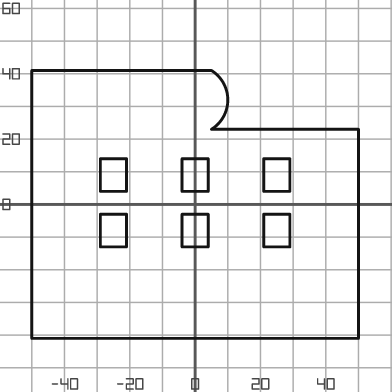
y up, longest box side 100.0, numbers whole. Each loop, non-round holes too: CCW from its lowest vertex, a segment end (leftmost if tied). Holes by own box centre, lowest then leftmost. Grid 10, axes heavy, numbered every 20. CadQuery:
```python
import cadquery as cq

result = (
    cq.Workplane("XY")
    .moveTo(-50.0, -41.0)
    .lineTo(50.0, -41.0)
    .lineTo(50.0, 23.0)
    .lineTo(5.0, 23.0)
    .threePointArc((10.0, 32.0), (5.0, 41.0))
    .lineTo(-50.0, 41.0)
    .close()
    .moveTo(-29.0, -13.0)
    .lineTo(-21.0, -13.0)
    .lineTo(-21.0, -3.0)
    .lineTo(-29.0, -3.0)
    .close()
    .moveTo(-4.0, -13.0)
    .lineTo(4.0, -13.0)
    .lineTo(4.0, -3.0)
    .lineTo(-4.0, -3.0)
    .close()
    .moveTo(21.0, -13.0)
    .lineTo(29.0, -13.0)
    .lineTo(29.0, -3.0)
    .lineTo(21.0, -3.0)
    .close()
    .moveTo(-29.0, 4.0)
    .lineTo(-21.0, 4.0)
    .lineTo(-21.0, 14.0)
    .lineTo(-29.0, 14.0)
    .close()
    .moveTo(-4.0, 4.0)
    .lineTo(4.0, 4.0)
    .lineTo(4.0, 14.0)
    .lineTo(-4.0, 14.0)
    .close()
    .moveTo(21.0, 4.0)
    .lineTo(29.0, 4.0)
    .lineTo(29.0, 14.0)
    .lineTo(21.0, 14.0)
    .close()
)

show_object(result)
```